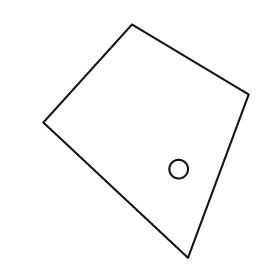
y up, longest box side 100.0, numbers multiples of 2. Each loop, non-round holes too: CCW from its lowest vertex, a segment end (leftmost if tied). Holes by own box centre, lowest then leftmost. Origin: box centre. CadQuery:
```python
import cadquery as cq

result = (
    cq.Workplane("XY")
    .moveTo(18.0, -50.0)
    .lineTo(44.0, 20.0)
    .lineTo(-6.0, 50.0)
    .lineTo(-44.0, 8.0)
    .close()
    .moveTo(14.0, -12.0)
    .circle(4.0)
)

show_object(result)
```